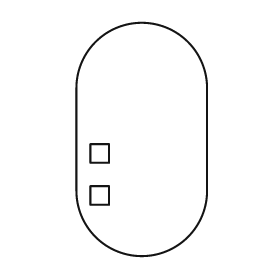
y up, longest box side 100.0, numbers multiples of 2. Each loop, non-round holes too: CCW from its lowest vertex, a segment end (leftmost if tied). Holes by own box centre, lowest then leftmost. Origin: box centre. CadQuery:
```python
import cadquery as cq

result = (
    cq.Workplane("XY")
    .moveTo(-28.0, -22.0)
    .threePointArc((0.0, -50.0), (28.0, -22.0))
    .lineTo(28.0, 22.0)
    .threePointArc((0.0, 50.0), (-28.0, 22.0))
    .close()
    .moveTo(-22.0, -28.0)
    .lineTo(-14.0, -28.0)
    .lineTo(-14.0, -20.0)
    .lineTo(-22.0, -20.0)
    .close()
    .moveTo(-22.0, -10.0)
    .lineTo(-14.0, -10.0)
    .lineTo(-14.0, -2.0)
    .lineTo(-22.0, -2.0)
    .close()
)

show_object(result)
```